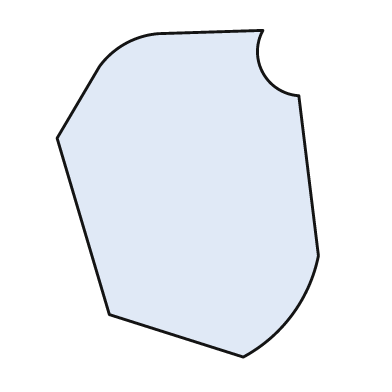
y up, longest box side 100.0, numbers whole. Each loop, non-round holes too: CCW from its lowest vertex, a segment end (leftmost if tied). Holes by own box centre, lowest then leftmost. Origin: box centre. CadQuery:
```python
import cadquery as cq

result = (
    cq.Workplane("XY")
    .moveTo(17.0, -50.0)
    .threePointArc((32.0, -37.0), (40.0, -19.0))
    .lineTo(34.0, 30.0)
    .threePointArc((23.0, 37.0), (23.0, 50.0))
    .lineTo(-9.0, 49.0)
    .threePointArc((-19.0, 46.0), (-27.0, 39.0))
    .lineTo(-40.0, 17.0)
    .lineTo(-24.0, -37.0)
    .close()
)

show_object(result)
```